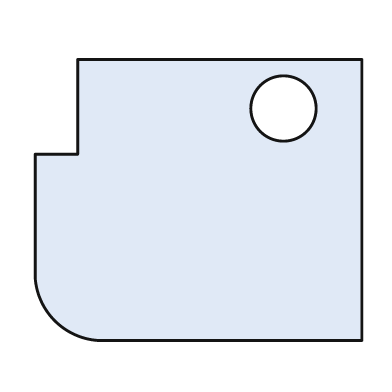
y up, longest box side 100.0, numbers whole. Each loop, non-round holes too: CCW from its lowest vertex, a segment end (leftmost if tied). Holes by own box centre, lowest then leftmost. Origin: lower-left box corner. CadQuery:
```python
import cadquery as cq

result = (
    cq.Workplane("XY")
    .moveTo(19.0, 0.0)
    .lineTo(100.0, 0.0)
    .lineTo(100.0, 86.0)
    .lineTo(13.0, 86.0)
    .lineTo(13.0, 57.0)
    .lineTo(0.0, 57.0)
    .lineTo(0.0, 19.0)
    .threePointArc((6.0, 6.0), (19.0, 0.0))
    .close()
    .moveTo(76.0, 71.0)
    .circle(10.0)
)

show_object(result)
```